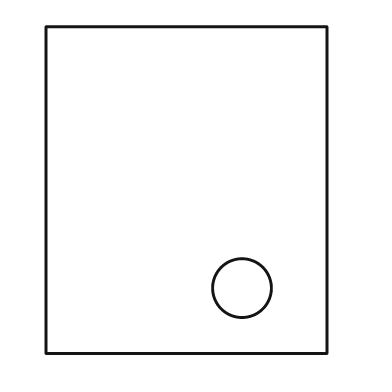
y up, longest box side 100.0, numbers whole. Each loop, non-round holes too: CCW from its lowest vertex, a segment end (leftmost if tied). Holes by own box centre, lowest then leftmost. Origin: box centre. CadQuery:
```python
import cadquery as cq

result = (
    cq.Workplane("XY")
    .moveTo(-43.0, -50.0)
    .lineTo(43.0, -50.0)
    .lineTo(43.0, 50.0)
    .lineTo(-43.0, 50.0)
    .close()
    .moveTo(17.0, -30.0)
    .circle(9.0)
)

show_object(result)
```